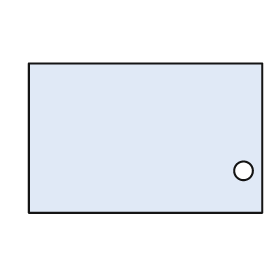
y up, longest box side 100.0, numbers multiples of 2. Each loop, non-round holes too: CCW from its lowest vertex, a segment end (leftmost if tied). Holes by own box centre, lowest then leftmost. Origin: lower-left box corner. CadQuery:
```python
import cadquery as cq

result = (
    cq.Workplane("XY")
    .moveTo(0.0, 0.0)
    .lineTo(100.0, 0.0)
    .lineTo(100.0, 64.0)
    .lineTo(0.0, 64.0)
    .close()
    .moveTo(92.0, 18.0)
    .circle(4.0)
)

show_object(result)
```